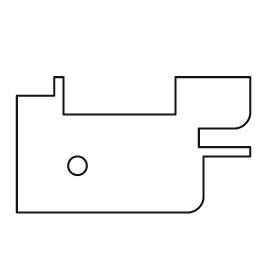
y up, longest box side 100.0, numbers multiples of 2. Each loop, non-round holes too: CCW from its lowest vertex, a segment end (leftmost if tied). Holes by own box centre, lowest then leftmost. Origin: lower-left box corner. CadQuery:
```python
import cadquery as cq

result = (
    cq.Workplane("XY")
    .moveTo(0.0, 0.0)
    .lineTo(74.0, 0.0)
    .threePointArc((78.0, 2.0), (80.0, 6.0))
    .lineTo(80.0, 24.0)
    .lineTo(100.0, 24.0)
    .lineTo(100.0, 28.0)
    .lineTo(78.0, 28.0)
    .lineTo(78.0, 36.0)
    .lineTo(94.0, 36.0)
    .threePointArc((98.0, 38.0), (100.0, 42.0))
    .lineTo(100.0, 58.0)
    .lineTo(68.0, 58.0)
    .lineTo(68.0, 42.0)
    .lineTo(20.0, 42.0)
    .lineTo(20.0, 58.0)
    .lineTo(16.0, 58.0)
    .lineTo(16.0, 50.0)
    .lineTo(0.0, 50.0)
    .close()
    .moveTo(26.0, 20.0)
    .circle(4.0)
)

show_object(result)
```